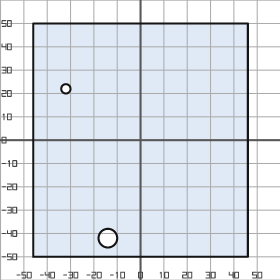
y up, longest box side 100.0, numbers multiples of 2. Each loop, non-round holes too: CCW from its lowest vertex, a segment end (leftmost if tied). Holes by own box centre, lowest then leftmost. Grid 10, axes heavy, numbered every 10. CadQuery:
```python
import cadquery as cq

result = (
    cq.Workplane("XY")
    .moveTo(-46.0, -50.0)
    .lineTo(46.0, -50.0)
    .lineTo(46.0, 50.0)
    .lineTo(-46.0, 50.0)
    .close()
    .moveTo(-14.0, -42.0)
    .circle(4.0)
    .moveTo(-32.0, 22.0)
    .circle(2.0)
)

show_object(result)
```